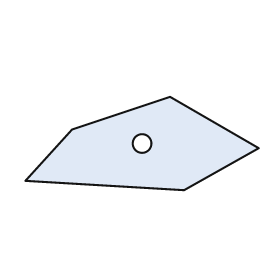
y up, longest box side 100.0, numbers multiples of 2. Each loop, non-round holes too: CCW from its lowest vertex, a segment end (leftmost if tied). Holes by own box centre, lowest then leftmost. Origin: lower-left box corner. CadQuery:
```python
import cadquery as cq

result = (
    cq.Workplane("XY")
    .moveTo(68.0, 0.0)
    .lineTo(100.0, 18.0)
    .lineTo(62.0, 40.0)
    .lineTo(20.0, 26.0)
    .lineTo(0.0, 4.0)
    .close()
    .moveTo(50.0, 20.0)
    .circle(4.0)
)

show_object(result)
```